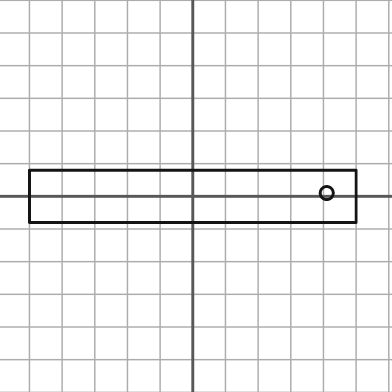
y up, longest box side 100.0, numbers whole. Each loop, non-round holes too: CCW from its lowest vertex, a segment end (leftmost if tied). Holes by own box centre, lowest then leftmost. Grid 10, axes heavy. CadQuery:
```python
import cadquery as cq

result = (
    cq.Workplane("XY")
    .moveTo(-50.0, -8.0)
    .lineTo(50.0, -8.0)
    .lineTo(50.0, 8.0)
    .lineTo(-50.0, 8.0)
    .close()
    .moveTo(41.0, 1.0)
    .circle(2.0)
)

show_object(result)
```